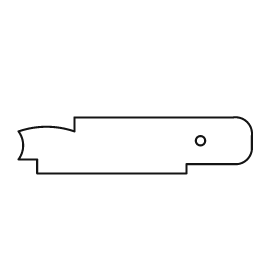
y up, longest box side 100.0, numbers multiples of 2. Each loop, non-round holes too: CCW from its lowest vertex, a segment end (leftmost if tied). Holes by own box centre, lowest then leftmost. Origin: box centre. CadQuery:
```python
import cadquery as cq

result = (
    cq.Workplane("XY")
    .moveTo(-42.0, -12.0)
    .lineTo(22.0, -12.0)
    .lineTo(22.0, -8.0)
    .lineTo(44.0, -8.0)
    .threePointArc((48.0, -6.0), (50.0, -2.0))
    .lineTo(50.0, 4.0)
    .threePointArc((48.0, 10.0), (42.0, 12.0))
    .lineTo(-26.0, 12.0)
    .lineTo(-26.0, 6.0)
    .threePointArc((-38.0, 8.0), (-50.0, 6.0))
    .threePointArc((-48.0, 0.0), (-50.0, -6.0))
    .lineTo(-42.0, -6.0)
    .close()
    .moveTo(28.0, 2.0)
    .circle(2.0)
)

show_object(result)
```